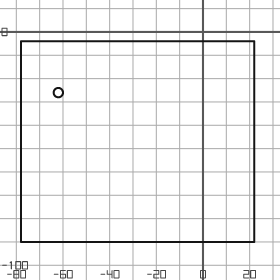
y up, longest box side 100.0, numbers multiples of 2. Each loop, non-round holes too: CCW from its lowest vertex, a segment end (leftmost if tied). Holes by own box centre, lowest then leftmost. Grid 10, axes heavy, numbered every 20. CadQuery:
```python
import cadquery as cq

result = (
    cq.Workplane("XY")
    .moveTo(-78.0, -90.0)
    .lineTo(22.0, -90.0)
    .lineTo(22.0, -4.0)
    .lineTo(-78.0, -4.0)
    .close()
    .moveTo(-62.0, -26.0)
    .circle(2.0)
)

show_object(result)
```